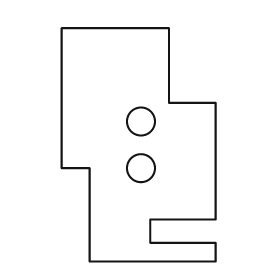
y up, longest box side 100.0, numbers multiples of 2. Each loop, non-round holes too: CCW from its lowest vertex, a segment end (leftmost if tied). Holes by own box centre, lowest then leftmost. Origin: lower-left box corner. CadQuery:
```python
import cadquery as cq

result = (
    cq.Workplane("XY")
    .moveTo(12.0, 0.0)
    .lineTo(66.0, 0.0)
    .lineTo(66.0, 8.0)
    .lineTo(38.0, 8.0)
    .lineTo(38.0, 18.0)
    .lineTo(66.0, 18.0)
    .lineTo(66.0, 68.0)
    .lineTo(46.0, 68.0)
    .lineTo(46.0, 100.0)
    .lineTo(0.0, 100.0)
    .lineTo(0.0, 40.0)
    .lineTo(12.0, 40.0)
    .close()
    .moveTo(34.0, 40.0)
    .circle(6.0)
    .moveTo(34.0, 60.0)
    .circle(6.0)
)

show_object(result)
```